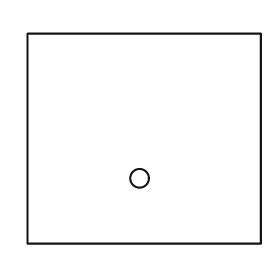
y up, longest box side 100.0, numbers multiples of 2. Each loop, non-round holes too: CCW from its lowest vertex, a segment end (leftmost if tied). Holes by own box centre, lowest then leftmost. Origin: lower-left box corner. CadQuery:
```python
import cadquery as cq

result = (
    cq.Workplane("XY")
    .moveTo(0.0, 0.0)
    .lineTo(100.0, 0.0)
    .lineTo(100.0, 90.0)
    .lineTo(0.0, 90.0)
    .close()
    .moveTo(48.0, 28.0)
    .circle(4.0)
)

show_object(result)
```